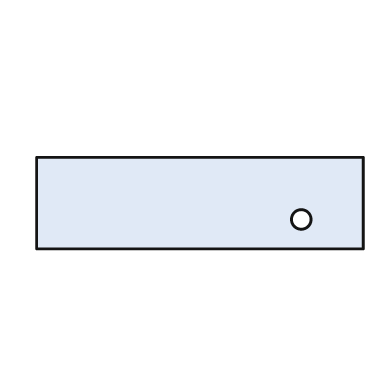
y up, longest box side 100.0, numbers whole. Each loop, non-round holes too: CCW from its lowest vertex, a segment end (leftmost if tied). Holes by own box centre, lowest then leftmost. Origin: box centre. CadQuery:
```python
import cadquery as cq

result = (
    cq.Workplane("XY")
    .moveTo(-50.0, -14.0)
    .lineTo(50.0, -14.0)
    .lineTo(50.0, 14.0)
    .lineTo(-50.0, 14.0)
    .close()
    .moveTo(31.0, -5.0)
    .circle(3.0)
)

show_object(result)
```